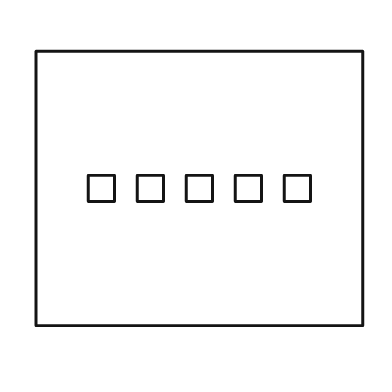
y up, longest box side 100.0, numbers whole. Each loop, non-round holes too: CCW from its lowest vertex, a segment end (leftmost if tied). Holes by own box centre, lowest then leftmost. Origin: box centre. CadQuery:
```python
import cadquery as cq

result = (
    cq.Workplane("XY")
    .moveTo(-50.0, -42.0)
    .lineTo(50.0, -42.0)
    .lineTo(50.0, 42.0)
    .lineTo(-50.0, 42.0)
    .close()
    .moveTo(-34.0, -4.0)
    .lineTo(-26.0, -4.0)
    .lineTo(-26.0, 4.0)
    .lineTo(-34.0, 4.0)
    .close()
    .moveTo(-19.0, -4.0)
    .lineTo(-11.0, -4.0)
    .lineTo(-11.0, 4.0)
    .lineTo(-19.0, 4.0)
    .close()
    .moveTo(-4.0, -4.0)
    .lineTo(4.0, -4.0)
    .lineTo(4.0, 4.0)
    .lineTo(-4.0, 4.0)
    .close()
    .moveTo(11.0, -4.0)
    .lineTo(19.0, -4.0)
    .lineTo(19.0, 4.0)
    .lineTo(11.0, 4.0)
    .close()
    .moveTo(26.0, -4.0)
    .lineTo(34.0, -4.0)
    .lineTo(34.0, 4.0)
    .lineTo(26.0, 4.0)
    .close()
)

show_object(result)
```